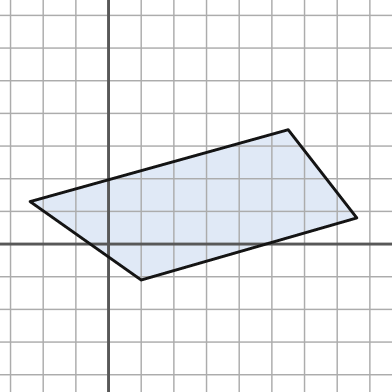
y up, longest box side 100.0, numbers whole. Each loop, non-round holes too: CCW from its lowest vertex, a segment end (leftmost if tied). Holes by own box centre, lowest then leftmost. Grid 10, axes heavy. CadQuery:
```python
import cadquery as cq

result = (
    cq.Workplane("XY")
    .moveTo(10.0, -11.0)
    .lineTo(76.0, 8.0)
    .lineTo(55.0, 35.0)
    .lineTo(-24.0, 13.0)
    .close()
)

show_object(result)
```